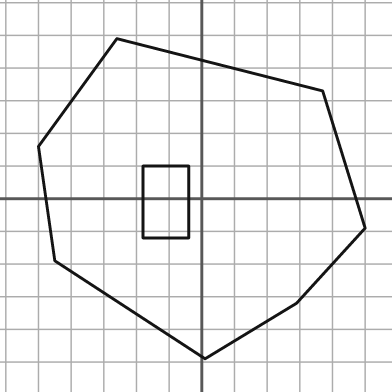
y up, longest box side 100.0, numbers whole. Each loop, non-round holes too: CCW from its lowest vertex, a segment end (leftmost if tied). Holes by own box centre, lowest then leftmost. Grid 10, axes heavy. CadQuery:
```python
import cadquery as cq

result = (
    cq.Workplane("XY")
    .moveTo(1.0, -49.0)
    .lineTo(29.0, -32.0)
    .lineTo(50.0, -9.0)
    .lineTo(37.0, 33.0)
    .lineTo(-26.0, 49.0)
    .lineTo(-50.0, 16.0)
    .lineTo(-45.0, -19.0)
    .close()
    .moveTo(-18.0, -12.0)
    .lineTo(-4.0, -12.0)
    .lineTo(-4.0, 10.0)
    .lineTo(-18.0, 10.0)
    .close()
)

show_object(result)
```